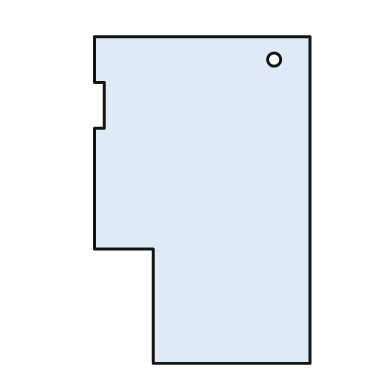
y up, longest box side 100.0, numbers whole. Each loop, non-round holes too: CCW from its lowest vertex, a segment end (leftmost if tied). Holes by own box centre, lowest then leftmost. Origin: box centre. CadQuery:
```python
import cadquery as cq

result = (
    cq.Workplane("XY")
    .moveTo(-15.0, -50.0)
    .lineTo(33.0, -50.0)
    .lineTo(33.0, 50.0)
    .lineTo(-33.0, 50.0)
    .lineTo(-33.0, 36.0)
    .lineTo(-30.0, 36.0)
    .lineTo(-30.0, 22.0)
    .lineTo(-33.0, 22.0)
    .lineTo(-33.0, -15.0)
    .lineTo(-15.0, -15.0)
    .close()
    .moveTo(22.0, 43.0)
    .circle(2.0)
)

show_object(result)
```